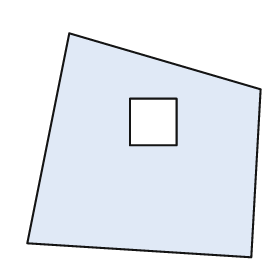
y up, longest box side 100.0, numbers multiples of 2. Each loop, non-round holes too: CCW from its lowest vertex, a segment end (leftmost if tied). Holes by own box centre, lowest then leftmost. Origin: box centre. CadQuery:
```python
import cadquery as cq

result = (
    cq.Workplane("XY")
    .moveTo(46.0, -48.0)
    .lineTo(50.0, 24.0)
    .lineTo(-32.0, 48.0)
    .lineTo(-50.0, -42.0)
    .close()
    .moveTo(-6.0, 0.0)
    .lineTo(14.0, 0.0)
    .lineTo(14.0, 20.0)
    .lineTo(-6.0, 20.0)
    .close()
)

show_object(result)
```